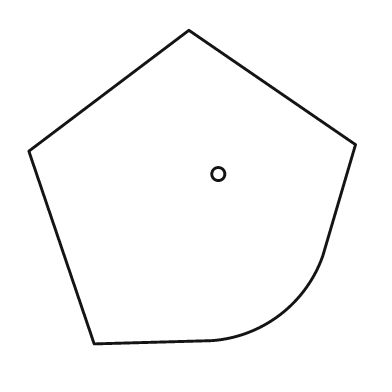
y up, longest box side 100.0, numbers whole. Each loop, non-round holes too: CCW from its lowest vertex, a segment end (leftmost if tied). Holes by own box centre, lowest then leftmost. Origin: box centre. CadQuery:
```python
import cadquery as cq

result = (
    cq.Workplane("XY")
    .moveTo(-30.0, -48.0)
    .lineTo(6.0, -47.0)
    .threePointArc((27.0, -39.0), (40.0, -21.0))
    .lineTo(50.0, 13.0)
    .lineTo(-1.0, 48.0)
    .lineTo(-50.0, 11.0)
    .close()
    .moveTo(8.0, 4.0)
    .circle(2.0)
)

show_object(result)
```